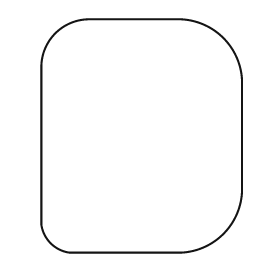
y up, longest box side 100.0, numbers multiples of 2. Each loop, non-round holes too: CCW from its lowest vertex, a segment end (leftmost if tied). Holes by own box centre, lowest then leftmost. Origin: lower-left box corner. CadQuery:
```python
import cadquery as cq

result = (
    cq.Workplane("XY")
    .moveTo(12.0, 0.0)
    .lineTo(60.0, 0.0)
    .threePointArc((78.0, 8.0), (86.0, 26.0))
    .lineTo(86.0, 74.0)
    .threePointArc((78.0, 92.0), (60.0, 100.0))
    .lineTo(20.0, 100.0)
    .threePointArc((6.0, 94.0), (0.0, 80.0))
    .lineTo(0.0, 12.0)
    .threePointArc((4.0, 4.0), (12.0, 0.0))
    .close()
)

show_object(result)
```